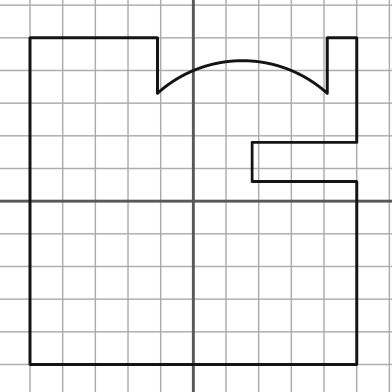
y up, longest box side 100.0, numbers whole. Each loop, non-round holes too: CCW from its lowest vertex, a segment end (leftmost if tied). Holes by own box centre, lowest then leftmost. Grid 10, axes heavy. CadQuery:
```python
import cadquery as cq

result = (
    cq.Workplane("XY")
    .moveTo(-50.0, -50.0)
    .lineTo(50.0, -50.0)
    .lineTo(50.0, 6.0)
    .lineTo(18.0, 6.0)
    .lineTo(18.0, 18.0)
    .lineTo(50.0, 18.0)
    .lineTo(50.0, 50.0)
    .lineTo(41.0, 50.0)
    .lineTo(41.0, 33.0)
    .threePointArc((15.0, 43.0), (-11.0, 33.0))
    .lineTo(-11.0, 50.0)
    .lineTo(-50.0, 50.0)
    .close()
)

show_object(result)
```